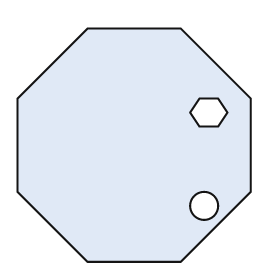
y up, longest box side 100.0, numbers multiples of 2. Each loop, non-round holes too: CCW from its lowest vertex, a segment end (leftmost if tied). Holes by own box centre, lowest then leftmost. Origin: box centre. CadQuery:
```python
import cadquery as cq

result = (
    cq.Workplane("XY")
    .moveTo(-20.0, -50.0)
    .lineTo(20.0, -50.0)
    .lineTo(50.0, -20.0)
    .lineTo(50.0, 20.0)
    .lineTo(20.0, 50.0)
    .lineTo(-20.0, 50.0)
    .lineTo(-50.0, 20.0)
    .lineTo(-50.0, -20.0)
    .close()
    .moveTo(30.0, -26.0)
    .circle(6.0)
    .moveTo(28.0, 8.0)
    .lineTo(36.0, 8.0)
    .lineTo(40.0, 14.0)
    .lineTo(36.0, 20.0)
    .lineTo(28.0, 20.0)
    .lineTo(24.0, 14.0)
    .close()
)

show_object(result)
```